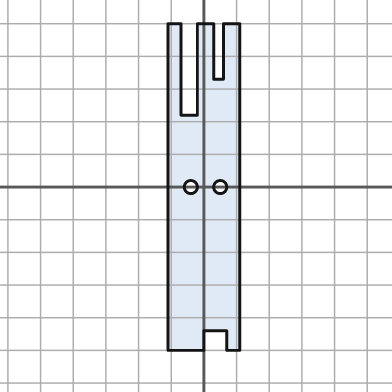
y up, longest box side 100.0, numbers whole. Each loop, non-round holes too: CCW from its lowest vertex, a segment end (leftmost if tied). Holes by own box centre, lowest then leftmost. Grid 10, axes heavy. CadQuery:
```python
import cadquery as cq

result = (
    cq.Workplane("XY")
    .moveTo(-11.0, -50.0)
    .lineTo(0.0, -50.0)
    .lineTo(0.0, -44.0)
    .lineTo(7.0, -44.0)
    .lineTo(7.0, -50.0)
    .lineTo(11.0, -50.0)
    .lineTo(11.0, 50.0)
    .lineTo(6.0, 50.0)
    .lineTo(6.0, 33.0)
    .lineTo(3.0, 33.0)
    .lineTo(3.0, 50.0)
    .lineTo(-2.0, 50.0)
    .lineTo(-2.0, 22.0)
    .lineTo(-7.0, 22.0)
    .lineTo(-7.0, 50.0)
    .lineTo(-11.0, 50.0)
    .close()
    .moveTo(-4.0, 0.0)
    .circle(2.0)
    .moveTo(5.0, 0.0)
    .circle(2.0)
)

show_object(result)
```